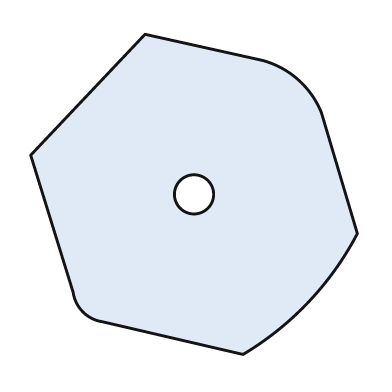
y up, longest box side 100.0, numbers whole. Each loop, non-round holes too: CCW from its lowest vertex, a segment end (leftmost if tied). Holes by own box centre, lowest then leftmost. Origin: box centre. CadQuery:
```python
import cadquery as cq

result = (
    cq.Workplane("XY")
    .moveTo(15.0, -49.0)
    .threePointArc((35.0, -33.0), (50.0, -12.0))
    .lineTo(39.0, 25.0)
    .threePointArc((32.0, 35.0), (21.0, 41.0))
    .lineTo(-15.0, 49.0)
    .lineTo(-50.0, 12.0)
    .lineTo(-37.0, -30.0)
    .threePointArc((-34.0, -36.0), (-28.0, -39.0))
    .close()
    .moveTo(0.0, 0.0)
    .circle(6.0)
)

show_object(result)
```